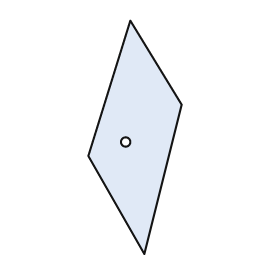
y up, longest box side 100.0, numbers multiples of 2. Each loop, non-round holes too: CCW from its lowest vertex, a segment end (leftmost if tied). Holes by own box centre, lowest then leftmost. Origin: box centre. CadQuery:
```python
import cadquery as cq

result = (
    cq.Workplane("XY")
    .moveTo(4.0, -50.0)
    .lineTo(20.0, 14.0)
    .lineTo(-2.0, 50.0)
    .lineTo(-20.0, -8.0)
    .close()
    .moveTo(-4.0, -2.0)
    .circle(2.0)
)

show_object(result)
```